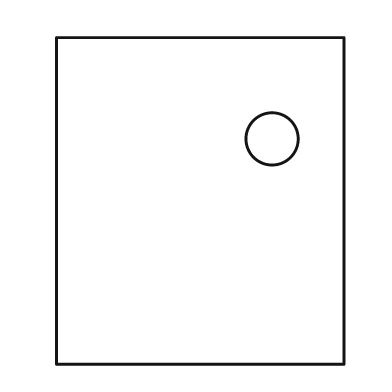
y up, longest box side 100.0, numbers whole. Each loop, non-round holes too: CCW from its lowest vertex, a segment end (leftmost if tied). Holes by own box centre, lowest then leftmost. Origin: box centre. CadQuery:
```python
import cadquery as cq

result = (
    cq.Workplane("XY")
    .moveTo(-44.0, -50.0)
    .lineTo(44.0, -50.0)
    .lineTo(44.0, 50.0)
    .lineTo(-44.0, 50.0)
    .close()
    .moveTo(22.0, 19.0)
    .circle(8.0)
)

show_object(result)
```